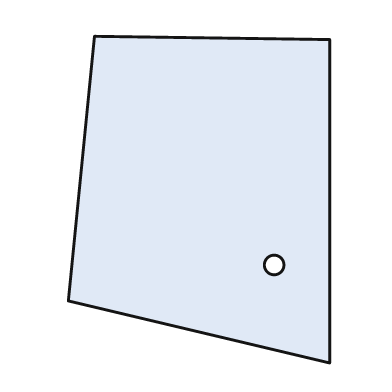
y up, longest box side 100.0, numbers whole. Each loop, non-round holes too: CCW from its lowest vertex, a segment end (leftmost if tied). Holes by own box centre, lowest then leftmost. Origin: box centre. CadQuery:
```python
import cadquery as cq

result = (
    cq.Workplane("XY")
    .moveTo(40.0, -50.0)
    .lineTo(40.0, 49.0)
    .lineTo(-32.0, 50.0)
    .lineTo(-40.0, -31.0)
    .close()
    .moveTo(23.0, -20.0)
    .circle(3.0)
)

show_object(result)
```